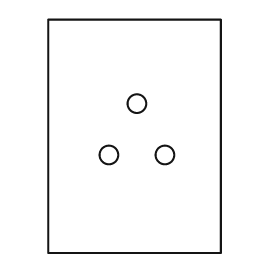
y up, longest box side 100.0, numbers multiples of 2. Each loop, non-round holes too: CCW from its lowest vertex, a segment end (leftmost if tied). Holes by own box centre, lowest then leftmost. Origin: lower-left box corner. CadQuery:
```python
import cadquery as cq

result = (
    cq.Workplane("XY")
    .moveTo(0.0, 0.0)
    .lineTo(74.0, 0.0)
    .lineTo(74.0, 100.0)
    .lineTo(0.0, 100.0)
    .close()
    .moveTo(26.0, 42.0)
    .circle(4.0)
    .moveTo(50.0, 42.0)
    .circle(4.0)
    .moveTo(38.0, 64.0)
    .circle(4.0)
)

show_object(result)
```